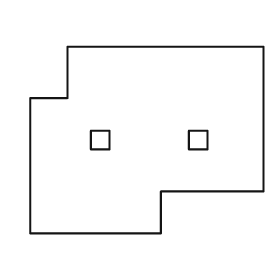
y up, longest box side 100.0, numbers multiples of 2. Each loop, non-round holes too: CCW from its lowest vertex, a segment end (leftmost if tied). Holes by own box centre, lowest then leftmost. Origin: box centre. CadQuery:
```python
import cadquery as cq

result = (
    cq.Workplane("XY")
    .moveTo(-50.0, -40.0)
    .lineTo(6.0, -40.0)
    .lineTo(6.0, -22.0)
    .lineTo(50.0, -22.0)
    .lineTo(50.0, 40.0)
    .lineTo(-34.0, 40.0)
    .lineTo(-34.0, 18.0)
    .lineTo(-50.0, 18.0)
    .close()
    .moveTo(-24.0, -4.0)
    .lineTo(-16.0, -4.0)
    .lineTo(-16.0, 4.0)
    .lineTo(-24.0, 4.0)
    .close()
    .moveTo(18.0, -4.0)
    .lineTo(26.0, -4.0)
    .lineTo(26.0, 4.0)
    .lineTo(18.0, 4.0)
    .close()
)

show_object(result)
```